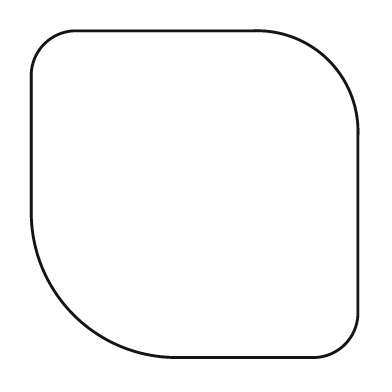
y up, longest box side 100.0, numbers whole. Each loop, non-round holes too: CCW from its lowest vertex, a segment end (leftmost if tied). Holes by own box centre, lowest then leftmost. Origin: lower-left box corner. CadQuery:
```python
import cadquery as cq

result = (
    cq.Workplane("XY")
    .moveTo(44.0, 0.0)
    .lineTo(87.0, 0.0)
    .threePointArc((96.0, 4.0), (100.0, 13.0))
    .lineTo(100.0, 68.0)
    .threePointArc((91.0, 91.0), (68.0, 100.0))
    .lineTo(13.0, 100.0)
    .threePointArc((4.0, 96.0), (0.0, 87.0))
    .lineTo(0.0, 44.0)
    .threePointArc((13.0, 13.0), (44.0, 0.0))
    .close()
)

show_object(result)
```